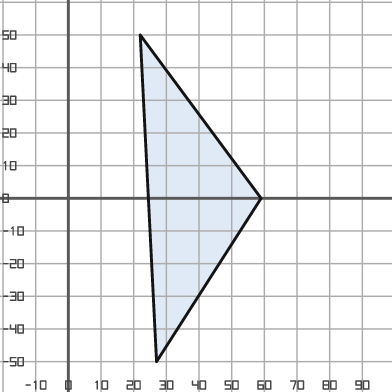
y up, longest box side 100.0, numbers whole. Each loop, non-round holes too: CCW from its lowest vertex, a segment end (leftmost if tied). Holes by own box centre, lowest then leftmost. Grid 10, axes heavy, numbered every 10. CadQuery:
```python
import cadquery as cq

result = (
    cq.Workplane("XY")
    .moveTo(27.0, -50.0)
    .lineTo(59.0, 0.0)
    .lineTo(22.0, 50.0)
    .close()
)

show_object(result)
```